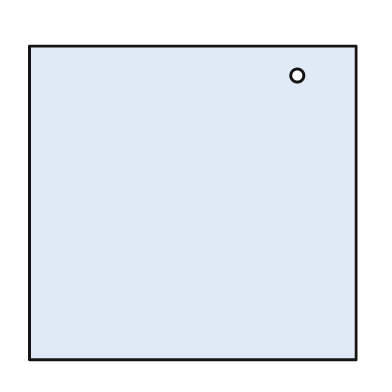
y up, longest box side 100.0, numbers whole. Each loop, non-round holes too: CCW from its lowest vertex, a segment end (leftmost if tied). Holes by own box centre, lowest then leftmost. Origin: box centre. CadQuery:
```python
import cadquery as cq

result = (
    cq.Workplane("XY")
    .moveTo(-50.0, -48.0)
    .lineTo(50.0, -48.0)
    .lineTo(50.0, 48.0)
    .lineTo(-50.0, 48.0)
    .close()
    .moveTo(32.0, 39.0)
    .circle(2.0)
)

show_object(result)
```